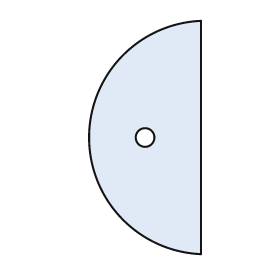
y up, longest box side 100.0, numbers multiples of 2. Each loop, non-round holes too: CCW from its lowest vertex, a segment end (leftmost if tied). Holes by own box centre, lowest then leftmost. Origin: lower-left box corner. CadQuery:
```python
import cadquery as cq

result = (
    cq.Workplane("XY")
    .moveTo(48.0, 0.0)
    .lineTo(48.0, 100.0)
    .threePointArc((0.0, 50.0), (48.0, 0.0))
    .close()
    .moveTo(24.0, 50.0)
    .circle(4.0)
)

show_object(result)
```